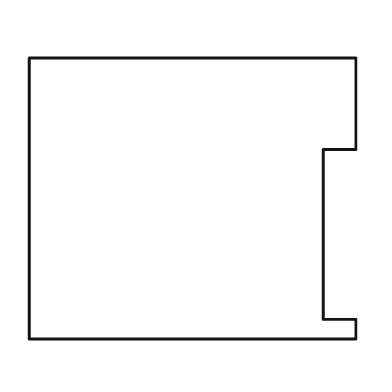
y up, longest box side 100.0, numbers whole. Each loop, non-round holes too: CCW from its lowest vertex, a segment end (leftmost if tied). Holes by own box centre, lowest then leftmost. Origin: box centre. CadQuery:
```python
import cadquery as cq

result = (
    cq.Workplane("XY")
    .moveTo(-50.0, -43.0)
    .lineTo(50.0, -43.0)
    .lineTo(50.0, -37.0)
    .lineTo(40.0, -37.0)
    .lineTo(40.0, 15.0)
    .lineTo(50.0, 15.0)
    .lineTo(50.0, 43.0)
    .lineTo(-50.0, 43.0)
    .close()
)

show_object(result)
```